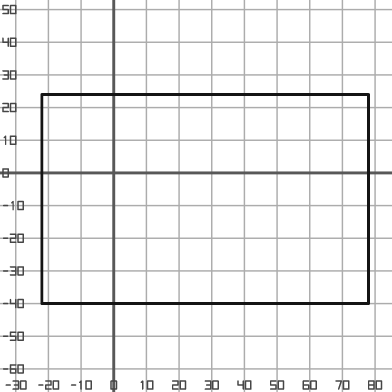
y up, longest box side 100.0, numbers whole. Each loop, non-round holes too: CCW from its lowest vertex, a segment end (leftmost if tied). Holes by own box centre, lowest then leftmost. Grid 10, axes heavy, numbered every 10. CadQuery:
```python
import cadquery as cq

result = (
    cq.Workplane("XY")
    .moveTo(-22.0, -40.0)
    .lineTo(78.0, -40.0)
    .lineTo(78.0, 24.0)
    .lineTo(-22.0, 24.0)
    .close()
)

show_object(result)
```